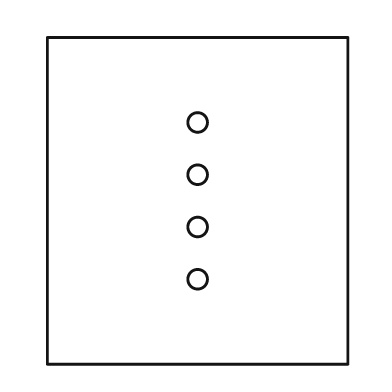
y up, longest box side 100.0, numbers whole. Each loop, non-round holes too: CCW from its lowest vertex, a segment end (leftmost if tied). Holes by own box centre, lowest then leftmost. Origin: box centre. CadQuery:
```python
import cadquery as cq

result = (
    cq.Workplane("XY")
    .moveTo(-46.0, -50.0)
    .lineTo(46.0, -50.0)
    .lineTo(46.0, 50.0)
    .lineTo(-46.0, 50.0)
    .close()
    .moveTo(0.0, -24.0)
    .circle(3.0)
    .moveTo(0.0, -8.0)
    .circle(3.0)
    .moveTo(0.0, 8.0)
    .circle(3.0)
    .moveTo(0.0, 24.0)
    .circle(3.0)
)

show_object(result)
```